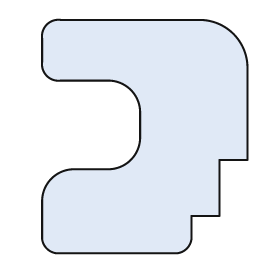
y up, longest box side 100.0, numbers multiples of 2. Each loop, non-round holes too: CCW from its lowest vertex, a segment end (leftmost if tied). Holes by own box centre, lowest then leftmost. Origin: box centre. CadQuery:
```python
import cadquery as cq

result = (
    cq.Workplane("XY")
    .moveTo(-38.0, -50.0)
    .lineTo(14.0, -50.0)
    .threePointArc((18.0, -48.0), (20.0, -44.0))
    .lineTo(20.0, -34.0)
    .lineTo(32.0, -34.0)
    .lineTo(32.0, -10.0)
    .lineTo(44.0, -10.0)
    .lineTo(44.0, 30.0)
    .threePointArc((38.0, 44.0), (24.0, 50.0))
    .lineTo(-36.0, 50.0)
    .threePointArc((-42.0, 48.0), (-44.0, 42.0))
    .lineTo(-44.0, 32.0)
    .threePointArc((-42.0, 26.0), (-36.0, 24.0))
    .lineTo(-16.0, 24.0)
    .threePointArc((-6.0, 20.0), (-2.0, 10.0))
    .lineTo(-2.0, 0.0)
    .threePointArc((-6.0, -10.0), (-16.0, -14.0))
    .lineTo(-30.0, -14.0)
    .threePointArc((-40.0, -18.0), (-44.0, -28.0))
    .lineTo(-44.0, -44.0)
    .threePointArc((-42.0, -48.0), (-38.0, -50.0))
    .close()
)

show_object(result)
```